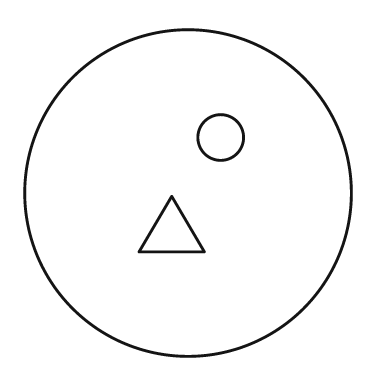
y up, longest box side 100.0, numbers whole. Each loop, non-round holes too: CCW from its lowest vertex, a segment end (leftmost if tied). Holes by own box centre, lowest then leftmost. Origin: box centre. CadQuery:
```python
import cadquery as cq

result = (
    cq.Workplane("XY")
    .moveTo(0.0, 0.0)
    .circle(50.0)
    .moveTo(-15.0, -18.0)
    .lineTo(5.0, -18.0)
    .lineTo(-5.0, -1.0)
    .close()
    .moveTo(10.0, 17.0)
    .circle(7.0)
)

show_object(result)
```